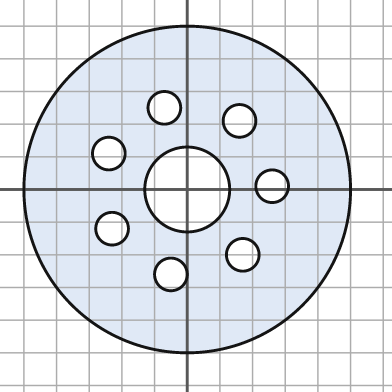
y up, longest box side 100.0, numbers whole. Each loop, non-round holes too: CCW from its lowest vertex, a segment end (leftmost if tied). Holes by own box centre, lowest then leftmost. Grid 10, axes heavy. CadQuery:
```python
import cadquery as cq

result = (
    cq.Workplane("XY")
    .moveTo(0.0, 0.0)
    .circle(50.0)
    .moveTo(-5.0, -26.0)
    .circle(5.0)
    .moveTo(17.0, -20.0)
    .circle(5.0)
    .moveTo(-23.0, -12.0)
    .circle(5.0)
    .moveTo(0.0, 0.0)
    .circle(13.0)
    .moveTo(26.0, 1.0)
    .circle(5.0)
    .moveTo(-24.0, 11.0)
    .circle(5.0)
    .moveTo(16.0, 21.0)
    .circle(5.0)
    .moveTo(-7.0, 25.0)
    .circle(5.0)
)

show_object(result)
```